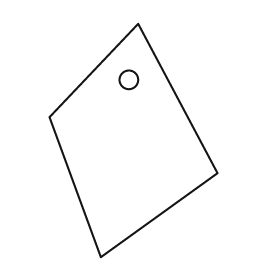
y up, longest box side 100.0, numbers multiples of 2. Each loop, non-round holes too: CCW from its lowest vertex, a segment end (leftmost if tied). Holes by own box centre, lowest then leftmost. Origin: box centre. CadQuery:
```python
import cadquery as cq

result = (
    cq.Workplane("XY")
    .moveTo(-14.0, -50.0)
    .lineTo(36.0, -14.0)
    .lineTo(2.0, 50.0)
    .lineTo(-36.0, 10.0)
    .close()
    .moveTo(-2.0, 26.0)
    .circle(4.0)
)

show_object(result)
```